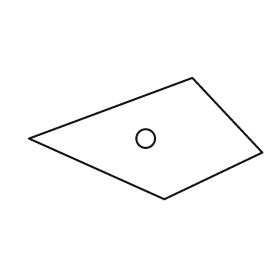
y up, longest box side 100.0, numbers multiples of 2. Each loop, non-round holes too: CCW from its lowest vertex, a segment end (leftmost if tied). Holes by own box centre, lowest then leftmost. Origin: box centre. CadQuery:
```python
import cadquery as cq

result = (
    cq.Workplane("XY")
    .moveTo(8.0, -26.0)
    .lineTo(50.0, -6.0)
    .lineTo(20.0, 26.0)
    .lineTo(-50.0, 0.0)
    .close()
    .moveTo(0.0, 0.0)
    .circle(4.0)
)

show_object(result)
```